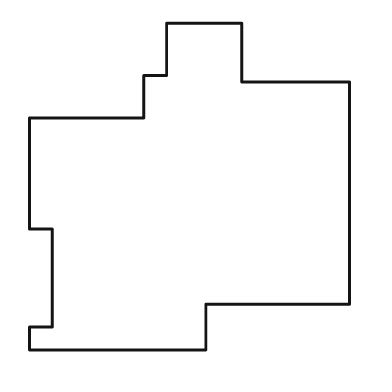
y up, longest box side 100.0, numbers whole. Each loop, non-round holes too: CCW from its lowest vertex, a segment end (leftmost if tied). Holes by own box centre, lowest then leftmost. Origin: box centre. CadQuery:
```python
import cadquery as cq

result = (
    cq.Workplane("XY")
    .moveTo(-49.0, -50.0)
    .lineTo(5.0, -50.0)
    .lineTo(5.0, -36.0)
    .lineTo(49.0, -36.0)
    .lineTo(49.0, 32.0)
    .lineTo(16.0, 32.0)
    .lineTo(16.0, 50.0)
    .lineTo(-7.0, 50.0)
    .lineTo(-7.0, 34.0)
    .lineTo(-14.0, 34.0)
    .lineTo(-14.0, 21.0)
    .lineTo(-49.0, 21.0)
    .lineTo(-49.0, -13.0)
    .lineTo(-42.0, -13.0)
    .lineTo(-42.0, -43.0)
    .lineTo(-49.0, -43.0)
    .close()
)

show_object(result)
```